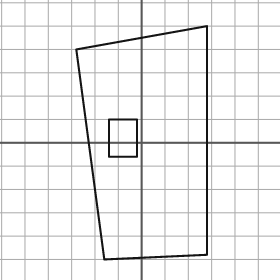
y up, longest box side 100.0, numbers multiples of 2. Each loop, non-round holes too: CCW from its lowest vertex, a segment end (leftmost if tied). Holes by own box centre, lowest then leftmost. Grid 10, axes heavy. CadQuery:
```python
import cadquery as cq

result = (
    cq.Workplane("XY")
    .moveTo(-16.0, -50.0)
    .lineTo(28.0, -48.0)
    .lineTo(28.0, 50.0)
    .lineTo(-28.0, 40.0)
    .close()
    .moveTo(-14.0, -6.0)
    .lineTo(-2.0, -6.0)
    .lineTo(-2.0, 10.0)
    .lineTo(-14.0, 10.0)
    .close()
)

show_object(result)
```